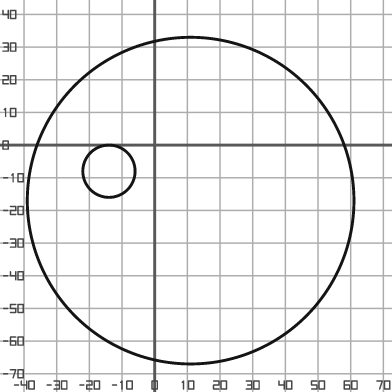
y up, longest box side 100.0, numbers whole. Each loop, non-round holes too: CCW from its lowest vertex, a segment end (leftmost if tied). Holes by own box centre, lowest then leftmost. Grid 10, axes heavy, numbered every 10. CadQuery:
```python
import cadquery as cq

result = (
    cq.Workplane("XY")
    .moveTo(11.0, -17.0)
    .circle(50.0)
    .moveTo(-14.0, -8.0)
    .circle(8.0)
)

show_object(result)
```